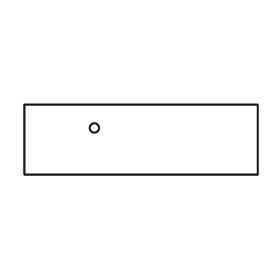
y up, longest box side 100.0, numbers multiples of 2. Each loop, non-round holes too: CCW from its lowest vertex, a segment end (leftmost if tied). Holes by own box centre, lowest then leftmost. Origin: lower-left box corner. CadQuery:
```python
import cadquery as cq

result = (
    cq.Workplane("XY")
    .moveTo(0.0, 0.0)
    .lineTo(100.0, 0.0)
    .lineTo(100.0, 30.0)
    .lineTo(0.0, 30.0)
    .close()
    .moveTo(30.0, 20.0)
    .circle(2.0)
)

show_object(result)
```